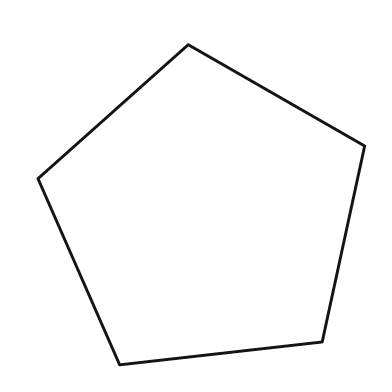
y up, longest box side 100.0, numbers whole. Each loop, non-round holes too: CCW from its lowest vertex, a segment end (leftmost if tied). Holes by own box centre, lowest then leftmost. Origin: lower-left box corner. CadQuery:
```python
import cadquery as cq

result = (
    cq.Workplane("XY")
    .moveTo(25.0, 0.0)
    .lineTo(87.0, 7.0)
    .lineTo(100.0, 67.0)
    .lineTo(46.0, 98.0)
    .lineTo(0.0, 57.0)
    .close()
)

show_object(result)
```